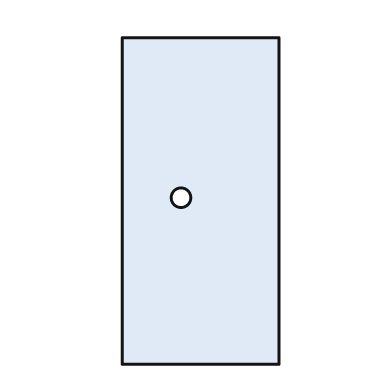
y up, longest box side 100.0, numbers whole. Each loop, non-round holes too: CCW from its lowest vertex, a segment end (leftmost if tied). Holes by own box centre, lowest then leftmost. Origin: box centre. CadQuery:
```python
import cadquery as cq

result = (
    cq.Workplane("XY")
    .moveTo(-24.0, -50.0)
    .lineTo(24.0, -50.0)
    .lineTo(24.0, 50.0)
    .lineTo(-24.0, 50.0)
    .close()
    .moveTo(-6.0, 1.0)
    .circle(3.0)
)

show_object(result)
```